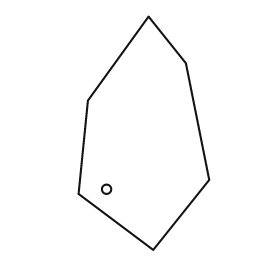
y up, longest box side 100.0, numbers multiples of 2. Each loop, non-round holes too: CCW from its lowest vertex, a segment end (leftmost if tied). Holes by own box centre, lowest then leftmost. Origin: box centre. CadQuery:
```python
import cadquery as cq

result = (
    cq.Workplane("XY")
    .moveTo(4.0, -50.0)
    .lineTo(28.0, -20.0)
    .lineTo(18.0, 30.0)
    .lineTo(2.0, 50.0)
    .lineTo(-24.0, 14.0)
    .lineTo(-28.0, -26.0)
    .close()
    .moveTo(-16.0, -24.0)
    .circle(2.0)
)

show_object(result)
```